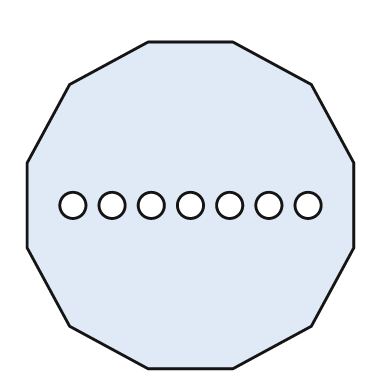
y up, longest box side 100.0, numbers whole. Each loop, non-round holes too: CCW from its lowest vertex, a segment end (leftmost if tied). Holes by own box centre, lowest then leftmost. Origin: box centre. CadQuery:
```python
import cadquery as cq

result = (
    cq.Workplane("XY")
    .moveTo(-13.0, -50.0)
    .lineTo(13.0, -50.0)
    .lineTo(37.0, -37.0)
    .lineTo(50.0, -13.0)
    .lineTo(50.0, 13.0)
    .lineTo(37.0, 37.0)
    .lineTo(13.0, 50.0)
    .lineTo(-13.0, 50.0)
    .lineTo(-37.0, 37.0)
    .lineTo(-50.0, 13.0)
    .lineTo(-50.0, -13.0)
    .lineTo(-37.0, -37.0)
    .close()
    .moveTo(-36.0, 0.0)
    .circle(4.0)
    .moveTo(-24.0, 0.0)
    .circle(4.0)
    .moveTo(-12.0, 0.0)
    .circle(4.0)
    .moveTo(0.0, 0.0)
    .circle(4.0)
    .moveTo(12.0, 0.0)
    .circle(4.0)
    .moveTo(24.0, 0.0)
    .circle(4.0)
    .moveTo(36.0, 0.0)
    .circle(4.0)
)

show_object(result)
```